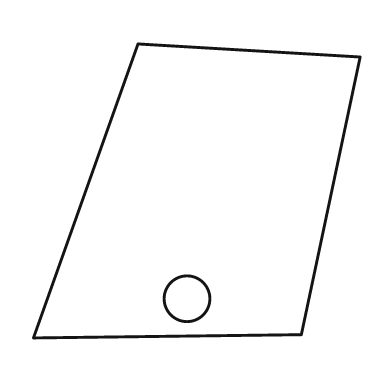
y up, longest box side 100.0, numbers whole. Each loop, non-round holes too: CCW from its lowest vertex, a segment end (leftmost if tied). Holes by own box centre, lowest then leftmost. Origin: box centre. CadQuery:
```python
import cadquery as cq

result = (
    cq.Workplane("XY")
    .moveTo(-50.0, -45.0)
    .lineTo(32.0, -44.0)
    .lineTo(50.0, 41.0)
    .lineTo(-18.0, 45.0)
    .close()
    .moveTo(-3.0, -33.0)
    .circle(7.0)
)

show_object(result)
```